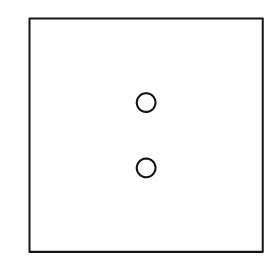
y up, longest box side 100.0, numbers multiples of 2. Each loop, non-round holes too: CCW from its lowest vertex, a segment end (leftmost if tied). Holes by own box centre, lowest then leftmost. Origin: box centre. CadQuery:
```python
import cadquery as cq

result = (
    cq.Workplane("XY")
    .moveTo(-50.0, -50.0)
    .lineTo(50.0, -50.0)
    .lineTo(50.0, 50.0)
    .lineTo(-50.0, 50.0)
    .close()
    .moveTo(0.0, -14.0)
    .circle(4.0)
    .moveTo(0.0, 14.0)
    .circle(4.0)
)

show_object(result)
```